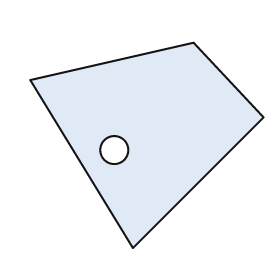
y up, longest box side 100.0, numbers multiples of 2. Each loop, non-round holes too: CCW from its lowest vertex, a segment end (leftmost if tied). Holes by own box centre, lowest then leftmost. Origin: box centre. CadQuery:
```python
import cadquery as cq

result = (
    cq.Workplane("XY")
    .moveTo(-6.0, -44.0)
    .lineTo(50.0, 12.0)
    .lineTo(20.0, 44.0)
    .lineTo(-50.0, 28.0)
    .close()
    .moveTo(-14.0, -2.0)
    .circle(6.0)
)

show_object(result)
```